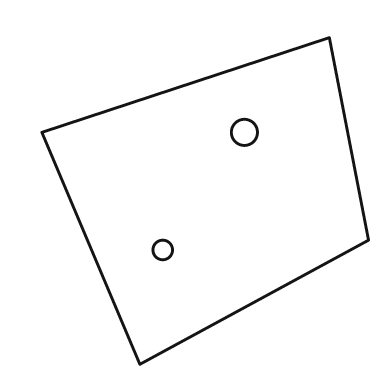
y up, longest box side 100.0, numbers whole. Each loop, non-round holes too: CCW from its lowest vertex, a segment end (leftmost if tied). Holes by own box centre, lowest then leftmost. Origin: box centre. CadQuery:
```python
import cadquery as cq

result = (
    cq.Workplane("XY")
    .moveTo(-20.0, -50.0)
    .lineTo(50.0, -12.0)
    .lineTo(38.0, 50.0)
    .lineTo(-50.0, 21.0)
    .close()
    .moveTo(-13.0, -15.0)
    .circle(3.0)
    .moveTo(12.0, 21.0)
    .circle(4.0)
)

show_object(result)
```